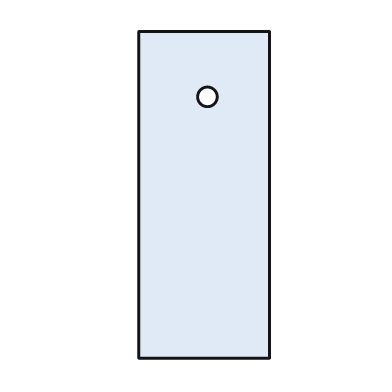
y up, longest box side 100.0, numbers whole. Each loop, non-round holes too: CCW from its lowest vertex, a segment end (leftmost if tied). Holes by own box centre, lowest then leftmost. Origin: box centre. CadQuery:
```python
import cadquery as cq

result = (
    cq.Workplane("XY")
    .moveTo(-20.0, -50.0)
    .lineTo(20.0, -50.0)
    .lineTo(20.0, 50.0)
    .lineTo(-20.0, 50.0)
    .close()
    .moveTo(1.0, 30.0)
    .circle(3.0)
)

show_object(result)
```